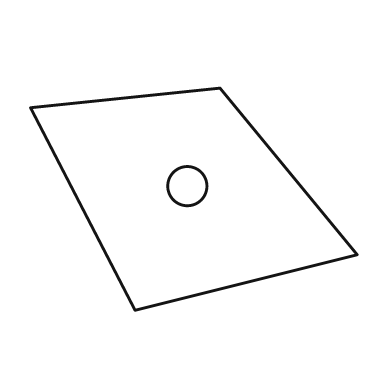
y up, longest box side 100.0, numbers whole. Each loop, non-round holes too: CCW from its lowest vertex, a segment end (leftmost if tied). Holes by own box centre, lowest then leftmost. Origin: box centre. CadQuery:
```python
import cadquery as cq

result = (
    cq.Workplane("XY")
    .moveTo(-18.0, -34.0)
    .lineTo(50.0, -17.0)
    .lineTo(8.0, 34.0)
    .lineTo(-50.0, 28.0)
    .close()
    .moveTo(-2.0, 4.0)
    .circle(6.0)
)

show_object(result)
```